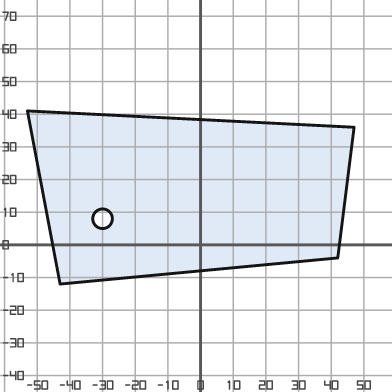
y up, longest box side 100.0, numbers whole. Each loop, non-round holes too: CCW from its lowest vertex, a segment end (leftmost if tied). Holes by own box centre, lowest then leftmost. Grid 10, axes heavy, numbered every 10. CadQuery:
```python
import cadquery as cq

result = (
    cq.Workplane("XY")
    .moveTo(-43.0, -12.0)
    .lineTo(42.0, -4.0)
    .lineTo(47.0, 36.0)
    .lineTo(-53.0, 41.0)
    .close()
    .moveTo(-30.0, 8.0)
    .circle(3.0)
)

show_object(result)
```